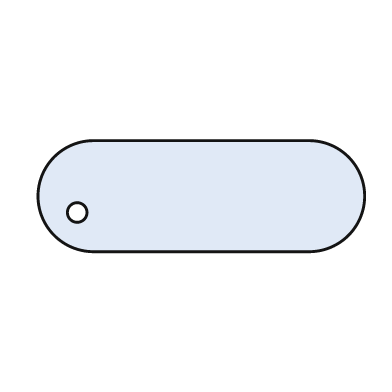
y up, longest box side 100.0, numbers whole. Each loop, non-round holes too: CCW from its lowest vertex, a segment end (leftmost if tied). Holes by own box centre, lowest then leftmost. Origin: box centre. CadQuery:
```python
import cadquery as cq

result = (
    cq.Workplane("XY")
    .moveTo(-33.0, -17.0)
    .lineTo(33.0, -17.0)
    .threePointArc((50.0, 0.0), (33.0, 17.0))
    .lineTo(-33.0, 17.0)
    .threePointArc((-50.0, 0.0), (-33.0, -17.0))
    .close()
    .moveTo(-38.0, -5.0)
    .circle(3.0)
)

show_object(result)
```